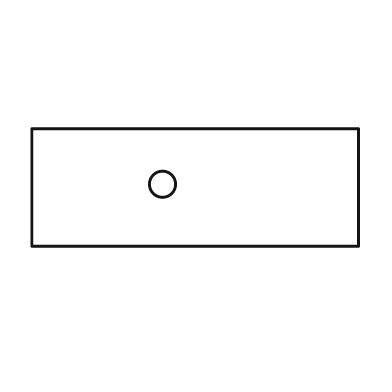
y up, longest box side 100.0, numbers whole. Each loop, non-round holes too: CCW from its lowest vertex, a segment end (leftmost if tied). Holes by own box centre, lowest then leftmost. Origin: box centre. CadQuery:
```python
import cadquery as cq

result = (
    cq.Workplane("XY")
    .moveTo(-50.0, -18.0)
    .lineTo(50.0, -18.0)
    .lineTo(50.0, 18.0)
    .lineTo(-50.0, 18.0)
    .close()
    .moveTo(-10.0, 1.0)
    .circle(4.0)
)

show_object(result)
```